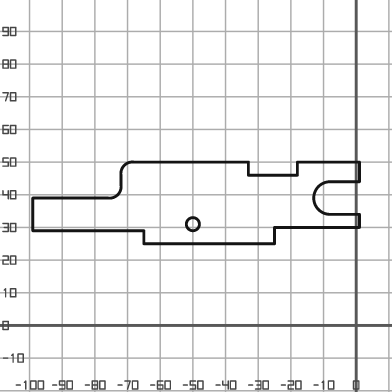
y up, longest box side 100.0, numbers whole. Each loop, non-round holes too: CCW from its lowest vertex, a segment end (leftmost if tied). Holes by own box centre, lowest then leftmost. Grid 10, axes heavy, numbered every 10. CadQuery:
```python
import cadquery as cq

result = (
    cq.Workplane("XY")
    .moveTo(-65.0, 25.0)
    .lineTo(-25.0, 25.0)
    .lineTo(-25.0, 30.0)
    .lineTo(1.0, 30.0)
    .lineTo(1.0, 34.0)
    .lineTo(-8.0, 34.0)
    .threePointArc((-13.0, 39.0), (-8.0, 44.0))
    .lineTo(1.0, 44.0)
    .lineTo(1.0, 50.0)
    .lineTo(-18.0, 50.0)
    .lineTo(-18.0, 46.0)
    .lineTo(-33.0, 46.0)
    .lineTo(-33.0, 50.0)
    .lineTo(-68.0, 50.0)
    .threePointArc((-71.0, 49.0), (-72.0, 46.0))
    .lineTo(-72.0, 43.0)
    .threePointArc((-73.0, 40.0), (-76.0, 39.0))
    .lineTo(-99.0, 39.0)
    .lineTo(-99.0, 29.0)
    .lineTo(-65.0, 29.0)
    .close()
    .moveTo(-50.0, 31.0)
    .circle(2.0)
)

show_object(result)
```